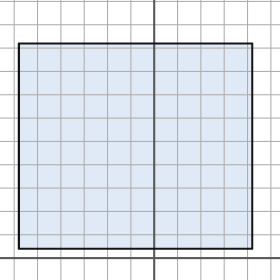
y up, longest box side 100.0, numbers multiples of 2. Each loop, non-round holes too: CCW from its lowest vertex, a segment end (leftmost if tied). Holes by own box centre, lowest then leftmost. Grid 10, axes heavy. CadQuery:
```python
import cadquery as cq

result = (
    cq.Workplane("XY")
    .moveTo(-58.0, 4.0)
    .lineTo(42.0, 4.0)
    .lineTo(42.0, 92.0)
    .lineTo(-58.0, 92.0)
    .close()
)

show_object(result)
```